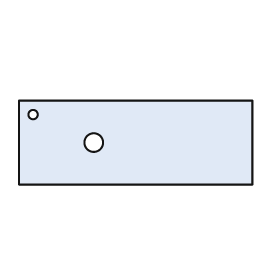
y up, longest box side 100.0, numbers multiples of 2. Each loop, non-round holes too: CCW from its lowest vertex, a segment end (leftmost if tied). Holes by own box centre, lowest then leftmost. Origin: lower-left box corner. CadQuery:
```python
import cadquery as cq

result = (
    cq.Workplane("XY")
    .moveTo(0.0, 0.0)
    .lineTo(100.0, 0.0)
    .lineTo(100.0, 36.0)
    .lineTo(0.0, 36.0)
    .close()
    .moveTo(32.0, 18.0)
    .circle(4.0)
    .moveTo(6.0, 30.0)
    .circle(2.0)
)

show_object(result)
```